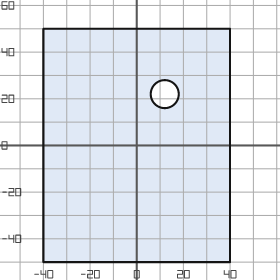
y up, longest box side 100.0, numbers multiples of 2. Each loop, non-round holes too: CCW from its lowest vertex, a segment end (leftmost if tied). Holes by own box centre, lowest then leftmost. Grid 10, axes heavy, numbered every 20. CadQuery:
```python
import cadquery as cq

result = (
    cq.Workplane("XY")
    .moveTo(-40.0, -50.0)
    .lineTo(40.0, -50.0)
    .lineTo(40.0, 50.0)
    .lineTo(-40.0, 50.0)
    .close()
    .moveTo(12.0, 22.0)
    .circle(6.0)
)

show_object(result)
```